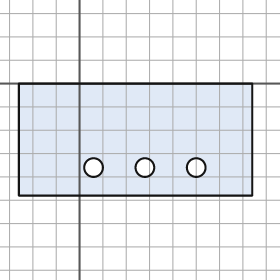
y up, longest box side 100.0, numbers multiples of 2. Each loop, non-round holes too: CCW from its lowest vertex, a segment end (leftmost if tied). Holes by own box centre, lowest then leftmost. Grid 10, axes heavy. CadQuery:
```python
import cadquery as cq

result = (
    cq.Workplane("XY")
    .moveTo(-26.0, -48.0)
    .lineTo(74.0, -48.0)
    .lineTo(74.0, 0.0)
    .lineTo(-26.0, 0.0)
    .close()
    .moveTo(6.0, -36.0)
    .circle(4.0)
    .moveTo(28.0, -36.0)
    .circle(4.0)
    .moveTo(50.0, -36.0)
    .circle(4.0)
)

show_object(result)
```